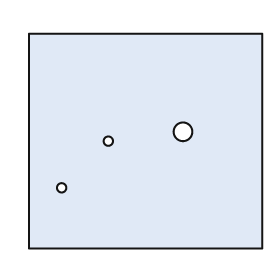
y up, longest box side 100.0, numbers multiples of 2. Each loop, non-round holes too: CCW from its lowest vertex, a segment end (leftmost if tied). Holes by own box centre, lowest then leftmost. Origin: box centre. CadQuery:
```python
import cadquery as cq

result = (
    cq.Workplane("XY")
    .moveTo(-50.0, -46.0)
    .lineTo(50.0, -46.0)
    .lineTo(50.0, 46.0)
    .lineTo(-50.0, 46.0)
    .close()
    .moveTo(-36.0, -20.0)
    .circle(2.0)
    .moveTo(-16.0, 0.0)
    .circle(2.0)
    .moveTo(16.0, 4.0)
    .circle(4.0)
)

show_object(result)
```